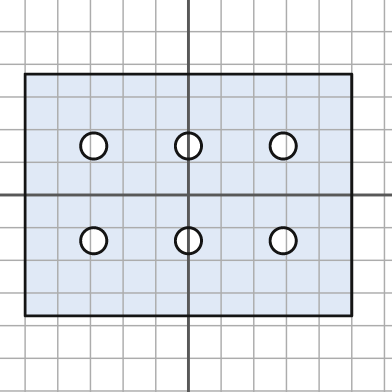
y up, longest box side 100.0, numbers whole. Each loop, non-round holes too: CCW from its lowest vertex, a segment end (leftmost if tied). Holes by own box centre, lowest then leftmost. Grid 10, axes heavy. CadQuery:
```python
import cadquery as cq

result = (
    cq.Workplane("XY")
    .moveTo(-50.0, -37.0)
    .lineTo(50.0, -37.0)
    .lineTo(50.0, 37.0)
    .lineTo(-50.0, 37.0)
    .close()
    .moveTo(-29.0, -14.0)
    .circle(4.0)
    .moveTo(0.0, -14.0)
    .circle(4.0)
    .moveTo(29.0, -14.0)
    .circle(4.0)
    .moveTo(-29.0, 15.0)
    .circle(4.0)
    .moveTo(0.0, 15.0)
    .circle(4.0)
    .moveTo(29.0, 15.0)
    .circle(4.0)
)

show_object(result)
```